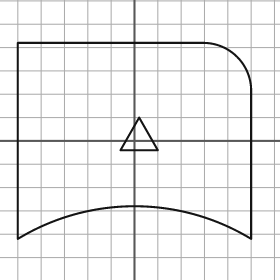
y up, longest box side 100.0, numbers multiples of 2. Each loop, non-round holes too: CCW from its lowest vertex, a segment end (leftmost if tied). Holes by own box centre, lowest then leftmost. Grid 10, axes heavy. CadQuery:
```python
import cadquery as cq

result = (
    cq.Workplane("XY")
    .moveTo(-50.0, -42.0)
    .threePointArc((0.0, -28.0), (50.0, -42.0))
    .lineTo(50.0, 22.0)
    .threePointArc((44.0, 36.0), (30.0, 42.0))
    .lineTo(-50.0, 42.0)
    .close()
    .moveTo(-6.0, -4.0)
    .lineTo(10.0, -4.0)
    .lineTo(2.0, 10.0)
    .close()
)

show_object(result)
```